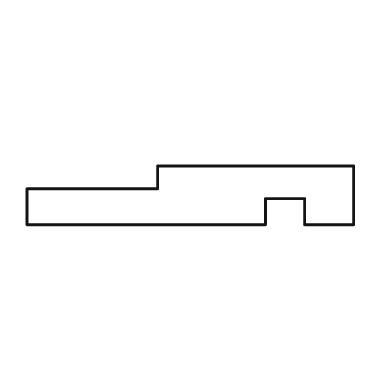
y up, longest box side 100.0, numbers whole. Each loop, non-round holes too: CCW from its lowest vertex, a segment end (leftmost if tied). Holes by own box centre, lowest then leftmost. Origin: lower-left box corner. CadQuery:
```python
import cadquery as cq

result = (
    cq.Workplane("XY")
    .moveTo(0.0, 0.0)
    .lineTo(73.0, 0.0)
    .lineTo(73.0, 8.0)
    .lineTo(85.0, 8.0)
    .lineTo(85.0, 0.0)
    .lineTo(100.0, 0.0)
    .lineTo(100.0, 18.0)
    .lineTo(40.0, 18.0)
    .lineTo(40.0, 11.0)
    .lineTo(0.0, 11.0)
    .close()
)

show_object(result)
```